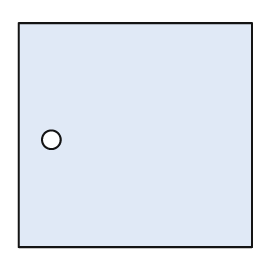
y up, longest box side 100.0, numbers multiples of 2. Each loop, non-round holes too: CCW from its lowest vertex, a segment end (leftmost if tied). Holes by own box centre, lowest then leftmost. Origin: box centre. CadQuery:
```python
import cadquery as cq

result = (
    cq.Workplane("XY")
    .moveTo(-50.0, -48.0)
    .lineTo(50.0, -48.0)
    .lineTo(50.0, 48.0)
    .lineTo(-50.0, 48.0)
    .close()
    .moveTo(-36.0, -2.0)
    .circle(4.0)
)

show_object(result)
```